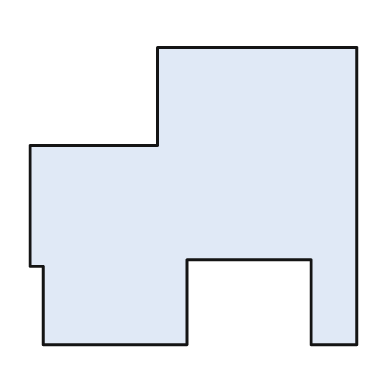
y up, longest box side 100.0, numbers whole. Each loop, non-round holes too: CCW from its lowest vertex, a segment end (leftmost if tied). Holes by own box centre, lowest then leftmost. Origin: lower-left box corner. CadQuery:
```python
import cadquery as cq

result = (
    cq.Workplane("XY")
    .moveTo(4.0, 0.0)
    .lineTo(48.0, 0.0)
    .lineTo(48.0, 26.0)
    .lineTo(86.0, 26.0)
    .lineTo(86.0, 0.0)
    .lineTo(100.0, 0.0)
    .lineTo(100.0, 91.0)
    .lineTo(39.0, 91.0)
    .lineTo(39.0, 61.0)
    .lineTo(0.0, 61.0)
    .lineTo(0.0, 24.0)
    .lineTo(4.0, 24.0)
    .close()
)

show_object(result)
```